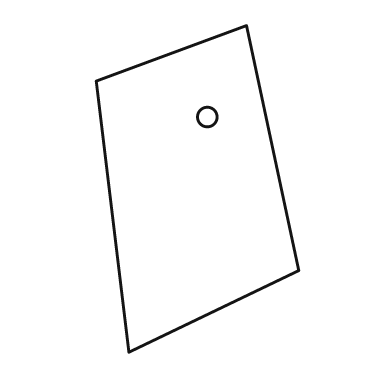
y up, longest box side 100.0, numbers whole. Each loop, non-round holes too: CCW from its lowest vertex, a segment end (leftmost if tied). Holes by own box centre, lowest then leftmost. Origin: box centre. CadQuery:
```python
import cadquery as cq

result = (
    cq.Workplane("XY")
    .moveTo(-21.0, -50.0)
    .lineTo(31.0, -25.0)
    .lineTo(15.0, 50.0)
    .lineTo(-31.0, 33.0)
    .close()
    .moveTo(3.0, 22.0)
    .circle(3.0)
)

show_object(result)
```